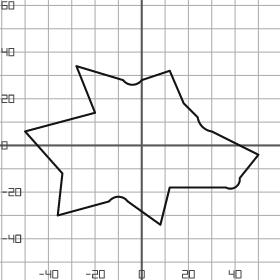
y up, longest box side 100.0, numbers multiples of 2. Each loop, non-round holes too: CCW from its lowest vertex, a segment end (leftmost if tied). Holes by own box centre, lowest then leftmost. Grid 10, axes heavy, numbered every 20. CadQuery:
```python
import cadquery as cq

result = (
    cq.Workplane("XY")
    .moveTo(8.0, -34.0)
    .lineTo(12.0, -18.0)
    .lineTo(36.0, -18.0)
    .threePointArc((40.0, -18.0), (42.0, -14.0))
    .lineTo(50.0, -4.0)
    .lineTo(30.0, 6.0)
    .threePointArc((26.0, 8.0), (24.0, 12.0))
    .lineTo(18.0, 18.0)
    .lineTo(12.0, 32.0)
    .lineTo(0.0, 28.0)
    .threePointArc((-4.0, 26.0), (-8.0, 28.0))
    .lineTo(-28.0, 34.0)
    .lineTo(-20.0, 14.0)
    .lineTo(-50.0, 6.0)
    .lineTo(-34.0, -12.0)
    .lineTo(-36.0, -30.0)
    .lineTo(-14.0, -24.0)
    .threePointArc((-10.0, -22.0), (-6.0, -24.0))
    .close()
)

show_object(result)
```